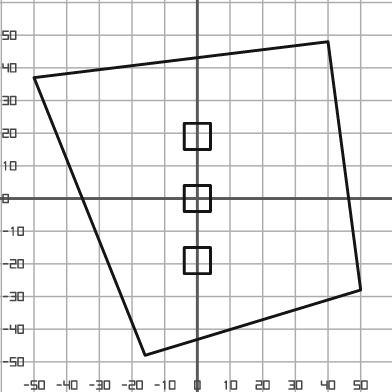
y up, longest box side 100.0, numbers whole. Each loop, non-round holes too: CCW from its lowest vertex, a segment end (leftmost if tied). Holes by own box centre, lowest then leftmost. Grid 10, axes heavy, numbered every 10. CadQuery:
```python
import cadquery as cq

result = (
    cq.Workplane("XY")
    .moveTo(-16.0, -48.0)
    .lineTo(50.0, -28.0)
    .lineTo(40.0, 48.0)
    .lineTo(-50.0, 37.0)
    .close()
    .moveTo(-4.0, -23.0)
    .lineTo(4.0, -23.0)
    .lineTo(4.0, -15.0)
    .lineTo(-4.0, -15.0)
    .close()
    .moveTo(-4.0, -4.0)
    .lineTo(4.0, -4.0)
    .lineTo(4.0, 4.0)
    .lineTo(-4.0, 4.0)
    .close()
    .moveTo(-4.0, 15.0)
    .lineTo(4.0, 15.0)
    .lineTo(4.0, 23.0)
    .lineTo(-4.0, 23.0)
    .close()
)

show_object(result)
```